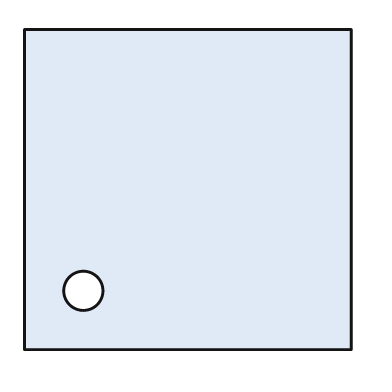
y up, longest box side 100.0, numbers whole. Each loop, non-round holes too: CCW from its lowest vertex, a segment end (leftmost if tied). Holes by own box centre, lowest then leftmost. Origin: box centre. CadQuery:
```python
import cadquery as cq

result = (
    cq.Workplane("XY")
    .moveTo(-50.0, -49.0)
    .lineTo(50.0, -49.0)
    .lineTo(50.0, 49.0)
    .lineTo(-50.0, 49.0)
    .close()
    .moveTo(-32.0, -31.0)
    .circle(6.0)
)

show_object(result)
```